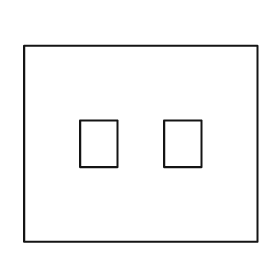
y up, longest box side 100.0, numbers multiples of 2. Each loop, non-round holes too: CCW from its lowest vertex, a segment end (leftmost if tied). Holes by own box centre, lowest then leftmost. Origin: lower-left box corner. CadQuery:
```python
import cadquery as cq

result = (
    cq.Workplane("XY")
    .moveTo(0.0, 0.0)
    .lineTo(100.0, 0.0)
    .lineTo(100.0, 84.0)
    .lineTo(0.0, 84.0)
    .close()
    .moveTo(24.0, 32.0)
    .lineTo(40.0, 32.0)
    .lineTo(40.0, 52.0)
    .lineTo(24.0, 52.0)
    .close()
    .moveTo(60.0, 32.0)
    .lineTo(76.0, 32.0)
    .lineTo(76.0, 52.0)
    .lineTo(60.0, 52.0)
    .close()
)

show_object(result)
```